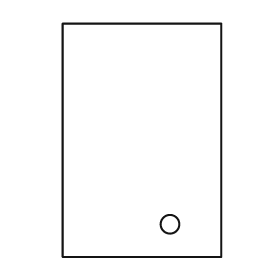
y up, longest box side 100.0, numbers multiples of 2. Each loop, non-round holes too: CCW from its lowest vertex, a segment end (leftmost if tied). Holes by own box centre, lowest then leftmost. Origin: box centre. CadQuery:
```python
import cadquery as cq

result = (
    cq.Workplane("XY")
    .moveTo(-34.0, -50.0)
    .lineTo(34.0, -50.0)
    .lineTo(34.0, 50.0)
    .lineTo(-34.0, 50.0)
    .close()
    .moveTo(12.0, -36.0)
    .circle(4.0)
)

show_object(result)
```